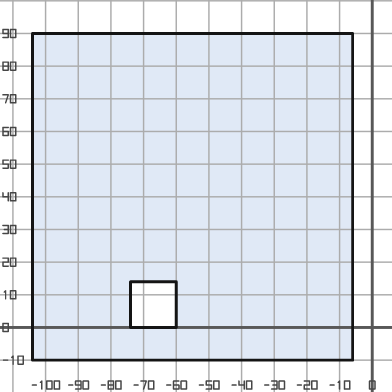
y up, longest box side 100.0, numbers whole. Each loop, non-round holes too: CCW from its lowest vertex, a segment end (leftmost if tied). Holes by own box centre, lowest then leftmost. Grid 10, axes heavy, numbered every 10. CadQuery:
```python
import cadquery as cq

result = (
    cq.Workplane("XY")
    .moveTo(-104.0, -10.0)
    .lineTo(-6.0, -10.0)
    .lineTo(-6.0, 90.0)
    .lineTo(-104.0, 90.0)
    .close()
    .moveTo(-74.0, 0.0)
    .lineTo(-60.0, 0.0)
    .lineTo(-60.0, 14.0)
    .lineTo(-74.0, 14.0)
    .close()
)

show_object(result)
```